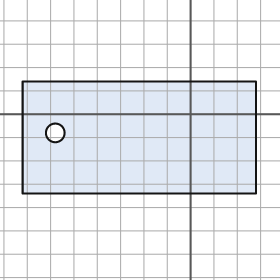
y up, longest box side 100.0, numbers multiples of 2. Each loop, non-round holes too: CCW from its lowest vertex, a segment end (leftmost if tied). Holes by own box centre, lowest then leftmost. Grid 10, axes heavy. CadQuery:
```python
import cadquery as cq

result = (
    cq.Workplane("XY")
    .moveTo(-72.0, -34.0)
    .lineTo(28.0, -34.0)
    .lineTo(28.0, 14.0)
    .lineTo(-72.0, 14.0)
    .close()
    .moveTo(-58.0, -8.0)
    .circle(4.0)
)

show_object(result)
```